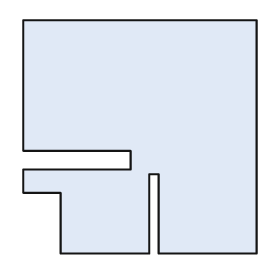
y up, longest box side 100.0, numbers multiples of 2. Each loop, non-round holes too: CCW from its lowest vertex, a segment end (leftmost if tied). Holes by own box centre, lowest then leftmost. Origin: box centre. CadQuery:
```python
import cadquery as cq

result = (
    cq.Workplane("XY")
    .moveTo(-34.0, -50.0)
    .lineTo(4.0, -50.0)
    .lineTo(4.0, -16.0)
    .lineTo(8.0, -16.0)
    .lineTo(8.0, -50.0)
    .lineTo(50.0, -50.0)
    .lineTo(50.0, 50.0)
    .lineTo(-50.0, 50.0)
    .lineTo(-50.0, -6.0)
    .lineTo(-4.0, -6.0)
    .lineTo(-4.0, -14.0)
    .lineTo(-50.0, -14.0)
    .lineTo(-50.0, -24.0)
    .lineTo(-34.0, -24.0)
    .close()
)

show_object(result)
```